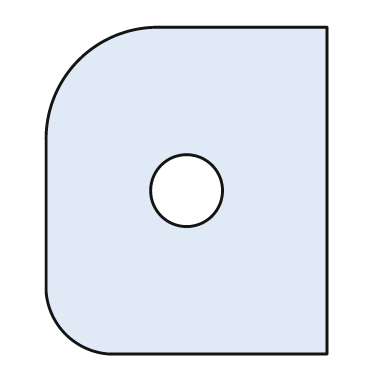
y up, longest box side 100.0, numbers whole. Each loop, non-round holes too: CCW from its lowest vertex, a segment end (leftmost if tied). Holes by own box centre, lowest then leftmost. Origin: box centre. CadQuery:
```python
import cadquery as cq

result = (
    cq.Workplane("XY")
    .moveTo(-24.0, -50.0)
    .lineTo(43.0, -50.0)
    .lineTo(43.0, 50.0)
    .lineTo(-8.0, 50.0)
    .threePointArc((-33.0, 40.0), (-43.0, 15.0))
    .lineTo(-43.0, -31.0)
    .threePointArc((-37.0, -44.0), (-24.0, -50.0))
    .close()
    .moveTo(0.0, 0.0)
    .circle(11.0)
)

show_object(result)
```